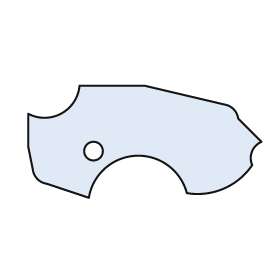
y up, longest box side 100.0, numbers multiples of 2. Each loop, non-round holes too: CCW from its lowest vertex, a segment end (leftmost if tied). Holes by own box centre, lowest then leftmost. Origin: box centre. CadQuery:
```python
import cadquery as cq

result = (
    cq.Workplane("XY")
    .moveTo(-24.0, -24.0)
    .threePointArc((-4.0, -6.0), (18.0, -22.0))
    .threePointArc((34.0, -20.0), (46.0, -10.0))
    .threePointArc((46.0, -4.0), (50.0, 0.0))
    .lineTo(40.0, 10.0)
    .threePointArc((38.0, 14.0), (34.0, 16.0))
    .lineTo(0.0, 24.0)
    .lineTo(-28.0, 24.0)
    .threePointArc((-36.0, 12.0), (-50.0, 12.0))
    .lineTo(-50.0, -2.0)
    .lineTo(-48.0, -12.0)
    .threePointArc((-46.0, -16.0), (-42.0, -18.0))
    .close()
    .moveTo(-22.0, -4.0)
    .circle(4.0)
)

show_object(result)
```